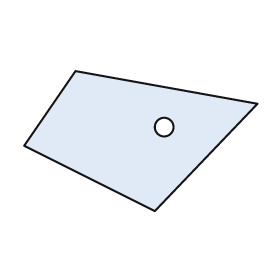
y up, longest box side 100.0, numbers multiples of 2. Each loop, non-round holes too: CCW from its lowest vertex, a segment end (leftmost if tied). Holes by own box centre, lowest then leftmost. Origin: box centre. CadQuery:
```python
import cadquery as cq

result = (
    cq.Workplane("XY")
    .moveTo(6.0, -30.0)
    .lineTo(50.0, 16.0)
    .lineTo(-28.0, 30.0)
    .lineTo(-50.0, -2.0)
    .close()
    .moveTo(10.0, 6.0)
    .circle(4.0)
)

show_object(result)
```